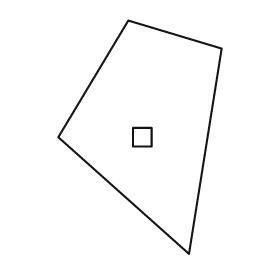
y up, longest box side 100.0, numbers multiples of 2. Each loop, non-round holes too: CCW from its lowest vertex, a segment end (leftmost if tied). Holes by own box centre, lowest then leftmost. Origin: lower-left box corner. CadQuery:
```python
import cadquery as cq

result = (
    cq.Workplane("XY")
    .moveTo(56.0, 0.0)
    .lineTo(70.0, 88.0)
    .lineTo(30.0, 100.0)
    .lineTo(0.0, 50.0)
    .close()
    .moveTo(32.0, 46.0)
    .lineTo(40.0, 46.0)
    .lineTo(40.0, 54.0)
    .lineTo(32.0, 54.0)
    .close()
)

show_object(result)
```